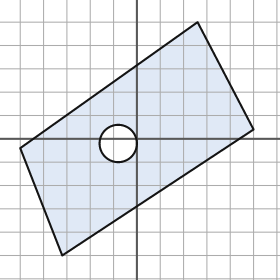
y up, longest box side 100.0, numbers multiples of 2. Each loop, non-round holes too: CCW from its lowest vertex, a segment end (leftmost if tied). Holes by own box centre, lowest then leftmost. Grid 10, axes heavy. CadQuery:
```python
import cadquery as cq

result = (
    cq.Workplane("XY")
    .moveTo(-32.0, -50.0)
    .lineTo(50.0, 4.0)
    .lineTo(26.0, 50.0)
    .lineTo(-50.0, -4.0)
    .close()
    .moveTo(-8.0, -2.0)
    .circle(8.0)
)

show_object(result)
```